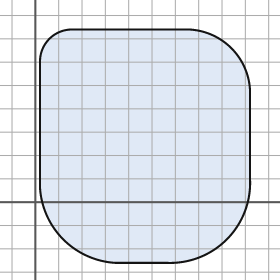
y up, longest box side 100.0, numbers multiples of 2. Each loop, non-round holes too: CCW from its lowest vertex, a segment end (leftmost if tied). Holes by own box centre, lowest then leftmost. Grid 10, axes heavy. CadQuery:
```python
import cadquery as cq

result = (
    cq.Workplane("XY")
    .moveTo(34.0, -26.0)
    .lineTo(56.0, -26.0)
    .threePointArc((82.0, -16.0), (92.0, 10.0))
    .lineTo(92.0, 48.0)
    .threePointArc((84.0, 66.0), (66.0, 74.0))
    .lineTo(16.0, 74.0)
    .threePointArc((6.0, 70.0), (2.0, 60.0))
    .lineTo(2.0, 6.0)
    .threePointArc((12.0, -16.0), (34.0, -26.0))
    .close()
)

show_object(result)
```